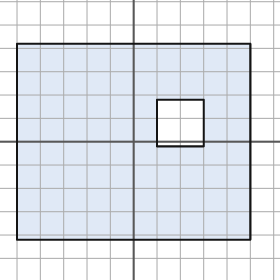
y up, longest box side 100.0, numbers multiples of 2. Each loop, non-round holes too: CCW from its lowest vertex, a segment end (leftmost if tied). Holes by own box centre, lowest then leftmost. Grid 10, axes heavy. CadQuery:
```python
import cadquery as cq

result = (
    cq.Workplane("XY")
    .moveTo(-50.0, -42.0)
    .lineTo(50.0, -42.0)
    .lineTo(50.0, 42.0)
    .lineTo(-50.0, 42.0)
    .close()
    .moveTo(10.0, -2.0)
    .lineTo(30.0, -2.0)
    .lineTo(30.0, 18.0)
    .lineTo(10.0, 18.0)
    .close()
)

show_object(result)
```